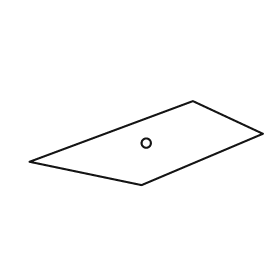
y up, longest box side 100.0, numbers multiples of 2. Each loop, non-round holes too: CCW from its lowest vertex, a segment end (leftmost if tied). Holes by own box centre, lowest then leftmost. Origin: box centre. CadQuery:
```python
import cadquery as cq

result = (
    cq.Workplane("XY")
    .moveTo(-2.0, -18.0)
    .lineTo(50.0, 4.0)
    .lineTo(20.0, 18.0)
    .lineTo(-50.0, -8.0)
    .close()
    .moveTo(0.0, 0.0)
    .circle(2.0)
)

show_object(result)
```